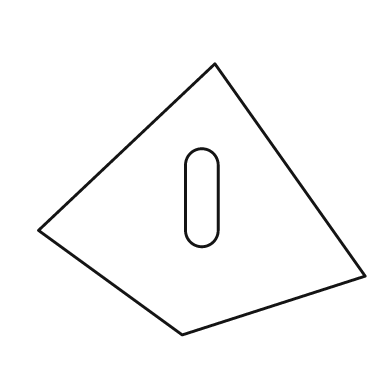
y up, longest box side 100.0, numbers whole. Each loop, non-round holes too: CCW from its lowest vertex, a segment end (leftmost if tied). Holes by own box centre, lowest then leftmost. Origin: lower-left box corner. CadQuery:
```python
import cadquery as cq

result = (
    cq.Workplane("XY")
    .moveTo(44.0, 0.0)
    .lineTo(100.0, 18.0)
    .lineTo(54.0, 83.0)
    .lineTo(0.0, 32.0)
    .close()
    .moveTo(45.0, 32.0)
    .threePointArc((50.0, 27.0), (55.0, 32.0))
    .lineTo(55.0, 52.0)
    .threePointArc((50.0, 57.0), (45.0, 52.0))
    .close()
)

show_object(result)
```